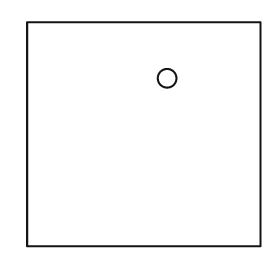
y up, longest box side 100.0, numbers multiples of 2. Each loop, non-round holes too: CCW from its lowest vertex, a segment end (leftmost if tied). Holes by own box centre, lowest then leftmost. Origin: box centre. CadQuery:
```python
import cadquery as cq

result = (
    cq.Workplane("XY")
    .moveTo(-50.0, -48.0)
    .lineTo(50.0, -48.0)
    .lineTo(50.0, 48.0)
    .lineTo(-50.0, 48.0)
    .close()
    .moveTo(10.0, 24.0)
    .circle(4.0)
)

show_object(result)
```